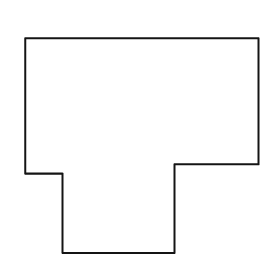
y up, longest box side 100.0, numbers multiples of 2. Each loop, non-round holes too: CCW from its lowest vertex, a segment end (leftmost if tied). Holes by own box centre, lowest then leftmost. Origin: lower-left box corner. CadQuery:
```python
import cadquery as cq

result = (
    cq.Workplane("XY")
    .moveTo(16.0, 0.0)
    .lineTo(64.0, 0.0)
    .lineTo(64.0, 38.0)
    .lineTo(100.0, 38.0)
    .lineTo(100.0, 92.0)
    .lineTo(0.0, 92.0)
    .lineTo(0.0, 34.0)
    .lineTo(16.0, 34.0)
    .close()
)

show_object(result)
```